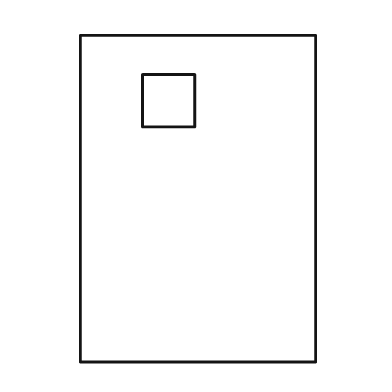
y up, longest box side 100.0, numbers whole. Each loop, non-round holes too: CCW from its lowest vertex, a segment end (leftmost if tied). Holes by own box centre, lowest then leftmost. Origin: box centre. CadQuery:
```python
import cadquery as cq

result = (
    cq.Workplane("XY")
    .moveTo(-36.0, -50.0)
    .lineTo(36.0, -50.0)
    .lineTo(36.0, 50.0)
    .lineTo(-36.0, 50.0)
    .close()
    .moveTo(-17.0, 22.0)
    .lineTo(-1.0, 22.0)
    .lineTo(-1.0, 38.0)
    .lineTo(-17.0, 38.0)
    .close()
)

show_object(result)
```